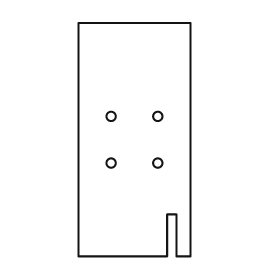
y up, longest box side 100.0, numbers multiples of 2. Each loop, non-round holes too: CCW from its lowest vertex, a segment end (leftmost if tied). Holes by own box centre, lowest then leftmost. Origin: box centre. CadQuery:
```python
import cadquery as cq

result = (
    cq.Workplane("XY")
    .moveTo(-24.0, -50.0)
    .lineTo(14.0, -50.0)
    .lineTo(14.0, -32.0)
    .lineTo(18.0, -32.0)
    .lineTo(18.0, -50.0)
    .lineTo(24.0, -50.0)
    .lineTo(24.0, 50.0)
    .lineTo(-24.0, 50.0)
    .close()
    .moveTo(-10.0, -10.0)
    .circle(2.0)
    .moveTo(10.0, -10.0)
    .circle(2.0)
    .moveTo(-10.0, 10.0)
    .circle(2.0)
    .moveTo(10.0, 10.0)
    .circle(2.0)
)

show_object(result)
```